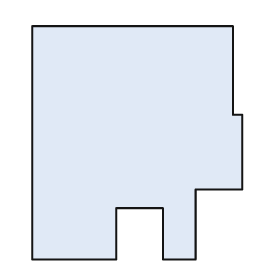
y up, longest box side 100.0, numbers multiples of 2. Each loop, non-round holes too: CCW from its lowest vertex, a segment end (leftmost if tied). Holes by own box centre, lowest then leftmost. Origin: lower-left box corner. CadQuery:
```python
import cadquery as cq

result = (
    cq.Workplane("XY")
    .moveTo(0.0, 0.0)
    .lineTo(36.0, 0.0)
    .lineTo(36.0, 22.0)
    .lineTo(56.0, 22.0)
    .lineTo(56.0, 0.0)
    .lineTo(70.0, 0.0)
    .lineTo(70.0, 30.0)
    .lineTo(90.0, 30.0)
    .lineTo(90.0, 62.0)
    .lineTo(86.0, 62.0)
    .lineTo(86.0, 100.0)
    .lineTo(0.0, 100.0)
    .close()
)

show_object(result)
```